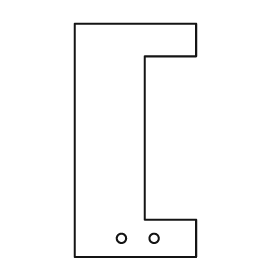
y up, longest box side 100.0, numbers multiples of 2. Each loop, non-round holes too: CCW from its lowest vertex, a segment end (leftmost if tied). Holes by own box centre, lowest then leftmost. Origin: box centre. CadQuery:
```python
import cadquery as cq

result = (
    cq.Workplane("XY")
    .moveTo(-26.0, -50.0)
    .lineTo(26.0, -50.0)
    .lineTo(26.0, -34.0)
    .lineTo(4.0, -34.0)
    .lineTo(4.0, 36.0)
    .lineTo(26.0, 36.0)
    .lineTo(26.0, 50.0)
    .lineTo(-26.0, 50.0)
    .close()
    .moveTo(-6.0, -42.0)
    .circle(2.0)
    .moveTo(8.0, -42.0)
    .circle(2.0)
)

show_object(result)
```